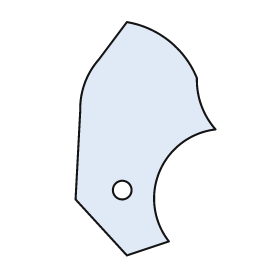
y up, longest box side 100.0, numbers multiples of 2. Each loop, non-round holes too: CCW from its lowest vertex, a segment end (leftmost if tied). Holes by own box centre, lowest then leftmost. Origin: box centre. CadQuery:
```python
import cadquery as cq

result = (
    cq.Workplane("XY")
    .moveTo(-8.0, -50.0)
    .lineTo(10.0, -44.0)
    .threePointArc((6.0, -14.0), (30.0, 4.0))
    .threePointArc((24.0, 14.0), (22.0, 26.0))
    .threePointArc((10.0, 42.0), (-8.0, 50.0))
    .lineTo(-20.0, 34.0)
    .threePointArc((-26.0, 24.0), (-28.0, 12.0))
    .lineTo(-30.0, -26.0)
    .close()
    .moveTo(-10.0, -22.0)
    .circle(4.0)
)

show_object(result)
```